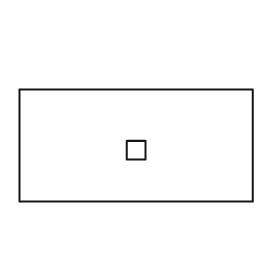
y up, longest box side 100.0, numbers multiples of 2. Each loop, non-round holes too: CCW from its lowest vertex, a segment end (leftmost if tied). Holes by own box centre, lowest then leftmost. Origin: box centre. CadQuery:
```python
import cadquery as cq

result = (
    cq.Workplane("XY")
    .moveTo(-50.0, -24.0)
    .lineTo(50.0, -24.0)
    .lineTo(50.0, 24.0)
    .lineTo(-50.0, 24.0)
    .close()
    .moveTo(-4.0, -6.0)
    .lineTo(4.0, -6.0)
    .lineTo(4.0, 2.0)
    .lineTo(-4.0, 2.0)
    .close()
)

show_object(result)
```